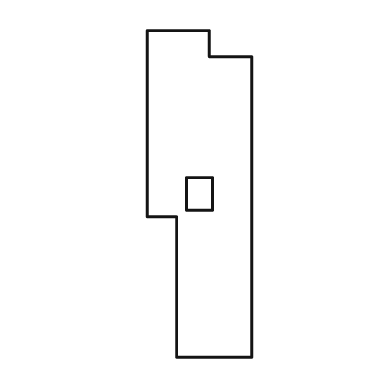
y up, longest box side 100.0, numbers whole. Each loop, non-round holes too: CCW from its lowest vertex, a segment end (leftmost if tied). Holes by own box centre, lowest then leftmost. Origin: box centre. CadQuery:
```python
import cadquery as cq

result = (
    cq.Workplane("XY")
    .moveTo(-7.0, -50.0)
    .lineTo(16.0, -50.0)
    .lineTo(16.0, 42.0)
    .lineTo(3.0, 42.0)
    .lineTo(3.0, 50.0)
    .lineTo(-16.0, 50.0)
    .lineTo(-16.0, -7.0)
    .lineTo(-7.0, -7.0)
    .close()
    .moveTo(-4.0, -5.0)
    .lineTo(4.0, -5.0)
    .lineTo(4.0, 5.0)
    .lineTo(-4.0, 5.0)
    .close()
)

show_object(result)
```